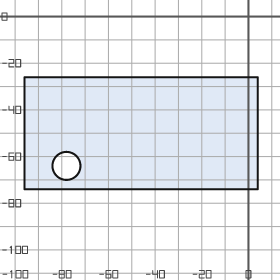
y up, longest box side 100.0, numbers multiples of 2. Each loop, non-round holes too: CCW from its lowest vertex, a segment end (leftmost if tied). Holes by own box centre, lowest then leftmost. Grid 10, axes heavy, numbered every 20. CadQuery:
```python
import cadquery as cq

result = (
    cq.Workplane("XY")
    .moveTo(-96.0, -74.0)
    .lineTo(4.0, -74.0)
    .lineTo(4.0, -26.0)
    .lineTo(-96.0, -26.0)
    .close()
    .moveTo(-78.0, -64.0)
    .circle(6.0)
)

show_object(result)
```